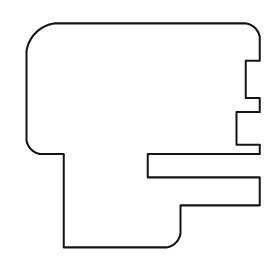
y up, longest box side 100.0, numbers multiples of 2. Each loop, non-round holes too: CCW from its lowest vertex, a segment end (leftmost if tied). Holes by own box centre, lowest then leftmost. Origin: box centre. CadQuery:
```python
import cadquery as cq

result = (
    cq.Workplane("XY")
    .moveTo(-34.0, -48.0)
    .lineTo(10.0, -48.0)
    .threePointArc((14.0, -46.0), (16.0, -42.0))
    .lineTo(16.0, -30.0)
    .lineTo(50.0, -30.0)
    .lineTo(50.0, -18.0)
    .lineTo(2.0, -18.0)
    .lineTo(2.0, -8.0)
    .lineTo(50.0, -8.0)
    .lineTo(50.0, -4.0)
    .lineTo(40.0, -4.0)
    .lineTo(40.0, 10.0)
    .lineTo(50.0, 10.0)
    .lineTo(50.0, 16.0)
    .lineTo(44.0, 16.0)
    .lineTo(44.0, 32.0)
    .lineTo(50.0, 32.0)
    .lineTo(50.0, 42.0)
    .threePointArc((48.0, 46.0), (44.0, 48.0))
    .lineTo(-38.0, 48.0)
    .threePointArc((-46.0, 44.0), (-50.0, 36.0))
    .lineTo(-50.0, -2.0)
    .threePointArc((-48.0, -6.0), (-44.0, -8.0))
    .lineTo(-34.0, -8.0)
    .close()
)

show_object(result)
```